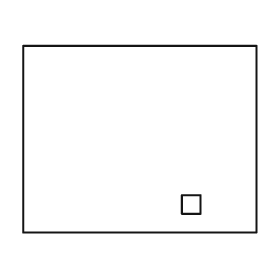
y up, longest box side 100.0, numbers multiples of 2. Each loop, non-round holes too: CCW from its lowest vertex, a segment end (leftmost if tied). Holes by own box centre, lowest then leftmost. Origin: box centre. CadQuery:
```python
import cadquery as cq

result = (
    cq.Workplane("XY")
    .moveTo(-50.0, -40.0)
    .lineTo(50.0, -40.0)
    .lineTo(50.0, 40.0)
    .lineTo(-50.0, 40.0)
    .close()
    .moveTo(18.0, -32.0)
    .lineTo(26.0, -32.0)
    .lineTo(26.0, -24.0)
    .lineTo(18.0, -24.0)
    .close()
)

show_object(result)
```